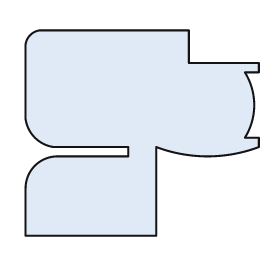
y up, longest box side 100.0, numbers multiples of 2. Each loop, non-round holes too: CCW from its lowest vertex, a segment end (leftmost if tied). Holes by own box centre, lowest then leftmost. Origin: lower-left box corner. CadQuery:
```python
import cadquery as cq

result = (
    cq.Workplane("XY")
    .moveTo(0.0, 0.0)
    .lineTo(56.0, 0.0)
    .lineTo(56.0, 38.0)
    .threePointArc((78.0, 34.0), (100.0, 38.0))
    .lineTo(100.0, 42.0)
    .lineTo(94.0, 42.0)
    .threePointArc((98.0, 56.0), (94.0, 70.0))
    .lineTo(100.0, 70.0)
    .lineTo(100.0, 74.0)
    .lineTo(70.0, 74.0)
    .lineTo(70.0, 88.0)
    .lineTo(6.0, 88.0)
    .threePointArc((2.0, 86.0), (0.0, 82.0))
    .lineTo(0.0, 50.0)
    .threePointArc((4.0, 42.0), (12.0, 38.0))
    .lineTo(44.0, 38.0)
    .lineTo(44.0, 34.0)
    .lineTo(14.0, 34.0)
    .threePointArc((4.0, 30.0), (0.0, 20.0))
    .close()
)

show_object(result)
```